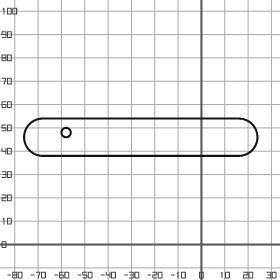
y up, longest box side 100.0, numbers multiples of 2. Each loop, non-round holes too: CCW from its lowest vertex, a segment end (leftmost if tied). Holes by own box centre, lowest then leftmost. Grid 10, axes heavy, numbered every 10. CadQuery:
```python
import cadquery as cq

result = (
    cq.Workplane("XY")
    .moveTo(-68.0, 38.0)
    .lineTo(16.0, 38.0)
    .threePointArc((24.0, 46.0), (16.0, 54.0))
    .lineTo(-68.0, 54.0)
    .threePointArc((-76.0, 46.0), (-68.0, 38.0))
    .close()
    .moveTo(-58.0, 48.0)
    .circle(2.0)
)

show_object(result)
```